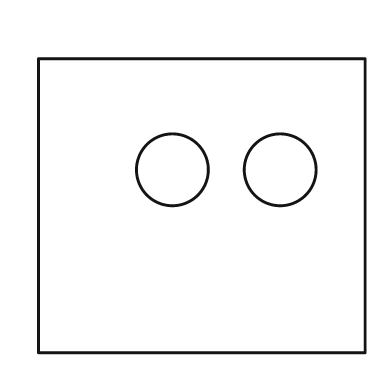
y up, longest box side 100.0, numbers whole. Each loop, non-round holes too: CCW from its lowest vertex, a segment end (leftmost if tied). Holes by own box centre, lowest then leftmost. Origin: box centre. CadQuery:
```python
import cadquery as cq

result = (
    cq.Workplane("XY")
    .moveTo(-50.0, -45.0)
    .lineTo(50.0, -45.0)
    .lineTo(50.0, 45.0)
    .lineTo(-50.0, 45.0)
    .close()
    .moveTo(-9.0, 11.0)
    .circle(11.0)
    .moveTo(24.0, 11.0)
    .circle(11.0)
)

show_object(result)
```